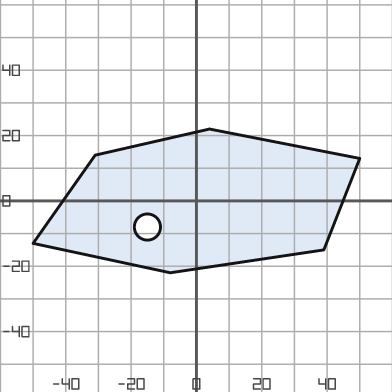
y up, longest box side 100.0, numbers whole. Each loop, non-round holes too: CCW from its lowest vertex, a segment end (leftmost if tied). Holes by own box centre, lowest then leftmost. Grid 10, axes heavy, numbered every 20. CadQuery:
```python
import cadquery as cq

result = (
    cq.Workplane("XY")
    .moveTo(-8.0, -22.0)
    .lineTo(39.0, -15.0)
    .lineTo(50.0, 13.0)
    .lineTo(4.0, 22.0)
    .lineTo(-31.0, 14.0)
    .lineTo(-50.0, -13.0)
    .close()
    .moveTo(-15.0, -8.0)
    .circle(4.0)
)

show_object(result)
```